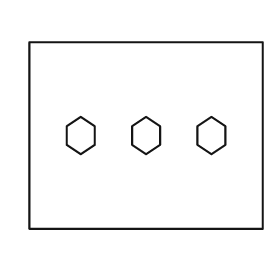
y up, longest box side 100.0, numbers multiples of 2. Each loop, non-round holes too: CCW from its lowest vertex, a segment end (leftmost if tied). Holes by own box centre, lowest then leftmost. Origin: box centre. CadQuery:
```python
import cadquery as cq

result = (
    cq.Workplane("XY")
    .moveTo(-50.0, -40.0)
    .lineTo(50.0, -40.0)
    .lineTo(50.0, 40.0)
    .lineTo(-50.0, 40.0)
    .close()
    .moveTo(-28.0, -8.0)
    .lineTo(-22.0, -4.0)
    .lineTo(-22.0, 4.0)
    .lineTo(-28.0, 8.0)
    .lineTo(-34.0, 4.0)
    .lineTo(-34.0, -4.0)
    .close()
    .moveTo(0.0, -8.0)
    .lineTo(6.0, -4.0)
    .lineTo(6.0, 4.0)
    .lineTo(0.0, 8.0)
    .lineTo(-6.0, 4.0)
    .lineTo(-6.0, -4.0)
    .close()
    .moveTo(28.0, -8.0)
    .lineTo(34.0, -4.0)
    .lineTo(34.0, 4.0)
    .lineTo(28.0, 8.0)
    .lineTo(22.0, 4.0)
    .lineTo(22.0, -4.0)
    .close()
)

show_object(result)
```